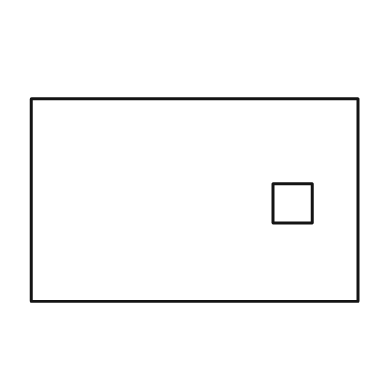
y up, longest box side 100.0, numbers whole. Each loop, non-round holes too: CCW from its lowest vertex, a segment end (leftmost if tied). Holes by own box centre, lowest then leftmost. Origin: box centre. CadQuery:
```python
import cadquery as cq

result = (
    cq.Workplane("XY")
    .moveTo(-50.0, -31.0)
    .lineTo(50.0, -31.0)
    .lineTo(50.0, 31.0)
    .lineTo(-50.0, 31.0)
    .close()
    .moveTo(24.0, -7.0)
    .lineTo(36.0, -7.0)
    .lineTo(36.0, 5.0)
    .lineTo(24.0, 5.0)
    .close()
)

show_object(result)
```